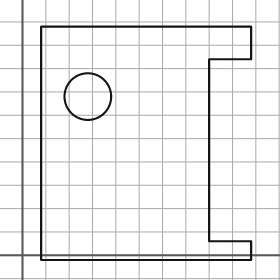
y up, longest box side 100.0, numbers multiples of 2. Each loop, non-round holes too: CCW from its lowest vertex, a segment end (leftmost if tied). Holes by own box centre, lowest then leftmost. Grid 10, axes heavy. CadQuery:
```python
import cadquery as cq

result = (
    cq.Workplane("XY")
    .moveTo(8.0, -2.0)
    .lineTo(98.0, -2.0)
    .lineTo(98.0, 6.0)
    .lineTo(80.0, 6.0)
    .lineTo(80.0, 84.0)
    .lineTo(98.0, 84.0)
    .lineTo(98.0, 98.0)
    .lineTo(8.0, 98.0)
    .close()
    .moveTo(28.0, 68.0)
    .circle(10.0)
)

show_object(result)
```